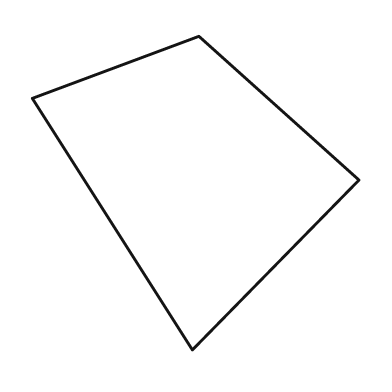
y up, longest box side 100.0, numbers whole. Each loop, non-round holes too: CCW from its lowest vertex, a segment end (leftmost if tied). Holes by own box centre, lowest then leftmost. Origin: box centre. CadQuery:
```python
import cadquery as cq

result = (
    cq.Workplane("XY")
    .moveTo(-1.0, -48.0)
    .lineTo(50.0, 4.0)
    .lineTo(1.0, 48.0)
    .lineTo(-50.0, 29.0)
    .close()
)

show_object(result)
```